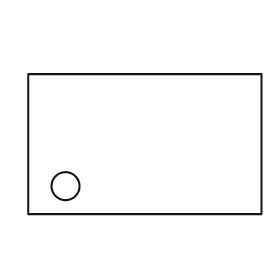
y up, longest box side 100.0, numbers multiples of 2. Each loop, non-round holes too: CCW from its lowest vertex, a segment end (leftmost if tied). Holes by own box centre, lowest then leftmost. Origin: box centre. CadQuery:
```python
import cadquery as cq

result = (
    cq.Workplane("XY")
    .moveTo(-50.0, -30.0)
    .lineTo(50.0, -30.0)
    .lineTo(50.0, 30.0)
    .lineTo(-50.0, 30.0)
    .close()
    .moveTo(-34.0, -18.0)
    .circle(6.0)
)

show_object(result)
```